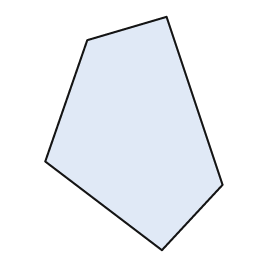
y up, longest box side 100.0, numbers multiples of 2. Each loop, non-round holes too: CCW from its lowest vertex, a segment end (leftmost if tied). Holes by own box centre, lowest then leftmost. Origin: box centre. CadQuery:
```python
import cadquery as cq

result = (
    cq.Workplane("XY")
    .moveTo(12.0, -50.0)
    .lineTo(38.0, -22.0)
    .lineTo(14.0, 50.0)
    .lineTo(-20.0, 40.0)
    .lineTo(-38.0, -12.0)
    .close()
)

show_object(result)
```